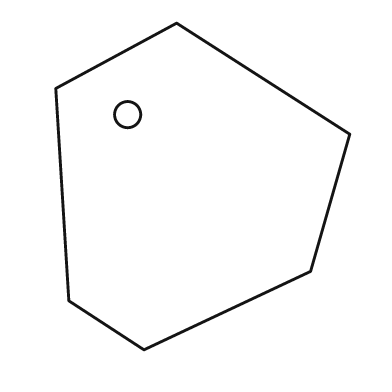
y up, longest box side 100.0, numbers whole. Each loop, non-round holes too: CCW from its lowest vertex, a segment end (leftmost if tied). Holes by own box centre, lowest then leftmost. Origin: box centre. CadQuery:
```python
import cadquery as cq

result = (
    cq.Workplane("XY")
    .moveTo(-18.0, -50.0)
    .lineTo(33.0, -26.0)
    .lineTo(45.0, 16.0)
    .lineTo(-8.0, 50.0)
    .lineTo(-45.0, 30.0)
    .lineTo(-41.0, -35.0)
    .close()
    .moveTo(-23.0, 22.0)
    .circle(4.0)
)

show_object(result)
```